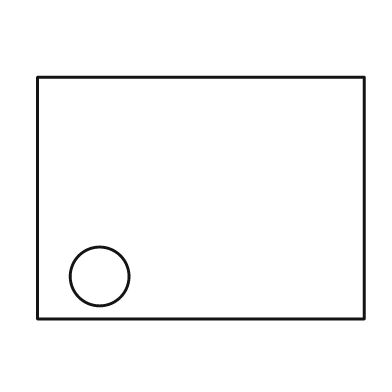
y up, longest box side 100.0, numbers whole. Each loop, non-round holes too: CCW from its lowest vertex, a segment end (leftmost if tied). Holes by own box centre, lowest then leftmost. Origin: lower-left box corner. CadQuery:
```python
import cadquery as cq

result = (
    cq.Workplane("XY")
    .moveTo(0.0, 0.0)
    .lineTo(100.0, 0.0)
    .lineTo(100.0, 74.0)
    .lineTo(0.0, 74.0)
    .close()
    .moveTo(19.0, 13.0)
    .circle(9.0)
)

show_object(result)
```